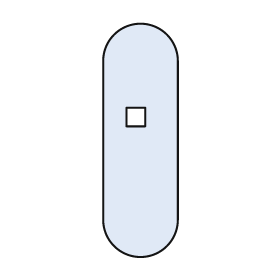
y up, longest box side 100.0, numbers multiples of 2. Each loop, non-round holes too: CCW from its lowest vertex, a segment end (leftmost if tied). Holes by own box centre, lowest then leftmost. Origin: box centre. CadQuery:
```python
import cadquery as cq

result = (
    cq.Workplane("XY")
    .moveTo(-16.0, -34.0)
    .threePointArc((0.0, -50.0), (16.0, -34.0))
    .lineTo(16.0, 34.0)
    .threePointArc((0.0, 50.0), (-16.0, 34.0))
    .close()
    .moveTo(-6.0, 6.0)
    .lineTo(2.0, 6.0)
    .lineTo(2.0, 14.0)
    .lineTo(-6.0, 14.0)
    .close()
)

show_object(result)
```